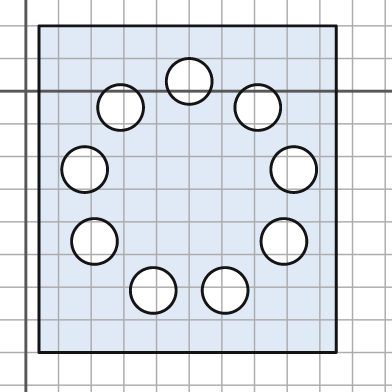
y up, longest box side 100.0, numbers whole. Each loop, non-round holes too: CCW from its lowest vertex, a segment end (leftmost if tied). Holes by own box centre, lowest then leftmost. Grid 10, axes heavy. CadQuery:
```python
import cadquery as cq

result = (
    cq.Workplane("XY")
    .moveTo(4.0, -80.0)
    .lineTo(95.0, -80.0)
    .lineTo(95.0, 20.0)
    .lineTo(4.0, 20.0)
    .close()
    .moveTo(39.0, -61.0)
    .circle(7.0)
    .moveTo(61.0, -61.0)
    .circle(7.0)
    .moveTo(21.0, -46.0)
    .circle(7.0)
    .moveTo(79.0, -46.0)
    .circle(7.0)
    .moveTo(18.0, -24.0)
    .circle(7.0)
    .moveTo(82.0, -24.0)
    .circle(7.0)
    .moveTo(29.0, -5.0)
    .circle(7.0)
    .moveTo(71.0, -5.0)
    .circle(7.0)
    .moveTo(50.0, 3.0)
    .circle(7.0)
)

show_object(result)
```